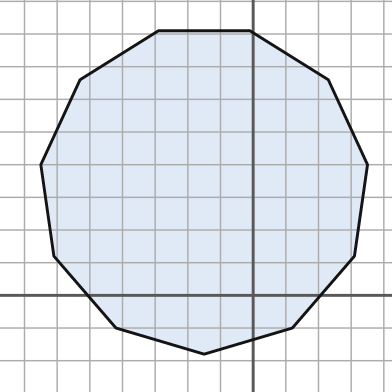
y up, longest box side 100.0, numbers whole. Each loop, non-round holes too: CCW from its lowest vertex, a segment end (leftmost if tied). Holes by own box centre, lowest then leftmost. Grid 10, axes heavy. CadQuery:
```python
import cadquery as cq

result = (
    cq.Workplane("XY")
    .moveTo(-15.0, -18.0)
    .lineTo(12.0, -10.0)
    .lineTo(31.0, 12.0)
    .lineTo(35.0, 40.0)
    .lineTo(23.0, 66.0)
    .lineTo(-1.0, 81.0)
    .lineTo(-29.0, 81.0)
    .lineTo(-53.0, 66.0)
    .lineTo(-65.0, 40.0)
    .lineTo(-61.0, 12.0)
    .lineTo(-42.0, -10.0)
    .close()
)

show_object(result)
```